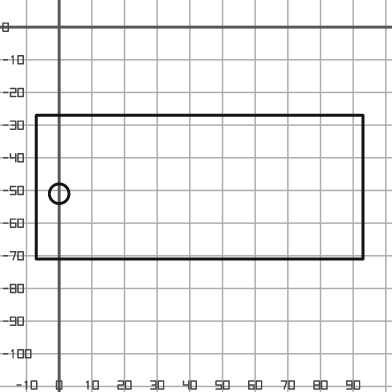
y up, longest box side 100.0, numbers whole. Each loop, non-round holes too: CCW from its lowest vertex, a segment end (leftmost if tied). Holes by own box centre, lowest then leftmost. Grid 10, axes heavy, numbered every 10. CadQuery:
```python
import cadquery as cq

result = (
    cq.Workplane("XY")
    .moveTo(-7.0, -71.0)
    .lineTo(93.0, -71.0)
    .lineTo(93.0, -27.0)
    .lineTo(-7.0, -27.0)
    .close()
    .moveTo(0.0, -51.0)
    .circle(3.0)
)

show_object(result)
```